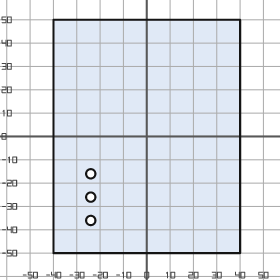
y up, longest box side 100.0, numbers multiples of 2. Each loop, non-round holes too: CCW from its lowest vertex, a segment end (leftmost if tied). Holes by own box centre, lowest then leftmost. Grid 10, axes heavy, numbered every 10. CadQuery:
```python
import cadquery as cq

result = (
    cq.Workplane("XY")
    .moveTo(-40.0, -50.0)
    .lineTo(40.0, -50.0)
    .lineTo(40.0, 50.0)
    .lineTo(-40.0, 50.0)
    .close()
    .moveTo(-24.0, -36.0)
    .circle(2.0)
    .moveTo(-24.0, -26.0)
    .circle(2.0)
    .moveTo(-24.0, -16.0)
    .circle(2.0)
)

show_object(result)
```